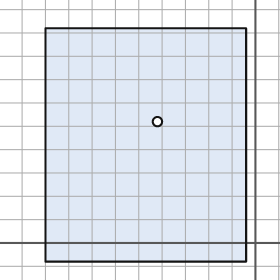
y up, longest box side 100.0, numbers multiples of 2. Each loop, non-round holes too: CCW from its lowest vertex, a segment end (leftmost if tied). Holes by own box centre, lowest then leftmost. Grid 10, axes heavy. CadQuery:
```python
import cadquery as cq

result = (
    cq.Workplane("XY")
    .moveTo(-90.0, -8.0)
    .lineTo(-4.0, -8.0)
    .lineTo(-4.0, 92.0)
    .lineTo(-90.0, 92.0)
    .close()
    .moveTo(-42.0, 52.0)
    .circle(2.0)
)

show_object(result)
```